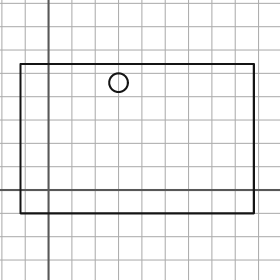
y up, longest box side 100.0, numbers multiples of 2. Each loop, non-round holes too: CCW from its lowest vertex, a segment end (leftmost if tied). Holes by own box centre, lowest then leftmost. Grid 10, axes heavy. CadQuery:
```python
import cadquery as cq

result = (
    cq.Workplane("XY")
    .moveTo(-12.0, -10.0)
    .lineTo(88.0, -10.0)
    .lineTo(88.0, 54.0)
    .lineTo(-12.0, 54.0)
    .close()
    .moveTo(30.0, 46.0)
    .circle(4.0)
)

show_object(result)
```